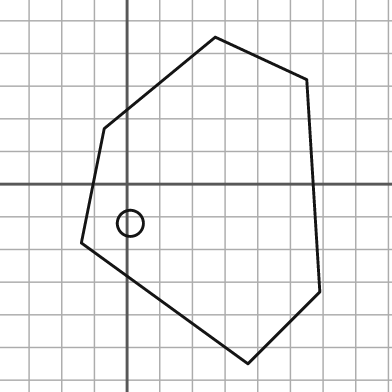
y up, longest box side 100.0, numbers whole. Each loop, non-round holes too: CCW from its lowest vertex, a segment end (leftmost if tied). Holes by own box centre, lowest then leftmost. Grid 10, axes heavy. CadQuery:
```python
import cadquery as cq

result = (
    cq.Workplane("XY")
    .moveTo(37.0, -55.0)
    .lineTo(59.0, -33.0)
    .lineTo(55.0, 32.0)
    .lineTo(27.0, 45.0)
    .lineTo(-7.0, 17.0)
    .lineTo(-14.0, -18.0)
    .close()
    .moveTo(1.0, -12.0)
    .circle(4.0)
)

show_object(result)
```